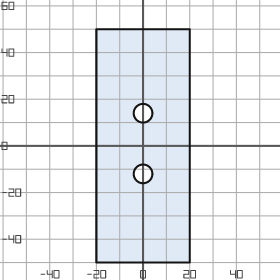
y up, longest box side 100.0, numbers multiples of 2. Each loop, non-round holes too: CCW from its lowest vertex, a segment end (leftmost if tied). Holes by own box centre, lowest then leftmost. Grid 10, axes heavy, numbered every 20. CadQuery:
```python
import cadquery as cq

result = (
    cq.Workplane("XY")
    .moveTo(-20.0, -50.0)
    .lineTo(20.0, -50.0)
    .lineTo(20.0, 50.0)
    .lineTo(-20.0, 50.0)
    .close()
    .moveTo(0.0, -12.0)
    .circle(4.0)
    .moveTo(0.0, 14.0)
    .circle(4.0)
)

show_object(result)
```